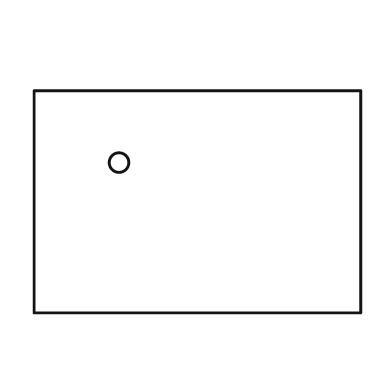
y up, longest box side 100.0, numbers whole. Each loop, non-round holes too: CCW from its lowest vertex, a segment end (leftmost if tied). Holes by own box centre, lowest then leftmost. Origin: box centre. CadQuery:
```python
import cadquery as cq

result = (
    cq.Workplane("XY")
    .moveTo(-50.0, -34.0)
    .lineTo(50.0, -34.0)
    .lineTo(50.0, 34.0)
    .lineTo(-50.0, 34.0)
    .close()
    .moveTo(-24.0, 12.0)
    .circle(3.0)
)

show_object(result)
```